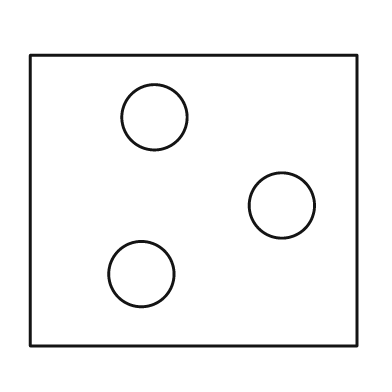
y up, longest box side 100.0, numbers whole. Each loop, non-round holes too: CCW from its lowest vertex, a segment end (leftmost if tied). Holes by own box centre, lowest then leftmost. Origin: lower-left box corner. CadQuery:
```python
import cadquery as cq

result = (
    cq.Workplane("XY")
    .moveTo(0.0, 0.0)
    .lineTo(100.0, 0.0)
    .lineTo(100.0, 89.0)
    .lineTo(0.0, 89.0)
    .close()
    .moveTo(34.0, 22.0)
    .circle(10.0)
    .moveTo(77.0, 43.0)
    .circle(10.0)
    .moveTo(38.0, 70.0)
    .circle(10.0)
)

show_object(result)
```